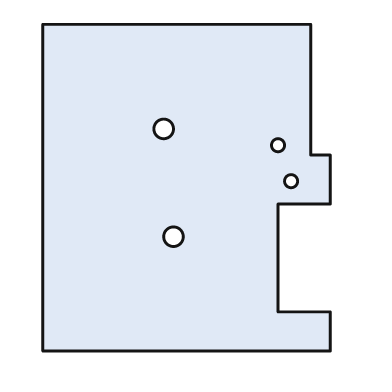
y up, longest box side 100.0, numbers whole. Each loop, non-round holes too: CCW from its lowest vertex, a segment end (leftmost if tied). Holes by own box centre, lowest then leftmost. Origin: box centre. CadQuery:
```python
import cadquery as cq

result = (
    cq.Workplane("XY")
    .moveTo(-44.0, -50.0)
    .lineTo(44.0, -50.0)
    .lineTo(44.0, -38.0)
    .lineTo(28.0, -38.0)
    .lineTo(28.0, -5.0)
    .lineTo(44.0, -5.0)
    .lineTo(44.0, 10.0)
    .lineTo(38.0, 10.0)
    .lineTo(38.0, 50.0)
    .lineTo(-44.0, 50.0)
    .close()
    .moveTo(-4.0, -15.0)
    .circle(3.0)
    .moveTo(32.0, 2.0)
    .circle(2.0)
    .moveTo(28.0, 13.0)
    .circle(2.0)
    .moveTo(-7.0, 18.0)
    .circle(3.0)
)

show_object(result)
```